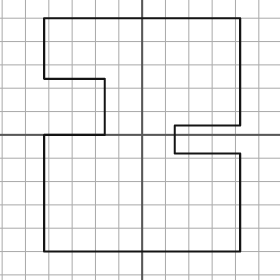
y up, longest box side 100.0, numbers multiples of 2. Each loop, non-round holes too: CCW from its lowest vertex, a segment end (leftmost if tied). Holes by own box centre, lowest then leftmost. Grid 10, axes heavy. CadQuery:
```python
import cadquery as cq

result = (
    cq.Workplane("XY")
    .moveTo(-42.0, -50.0)
    .lineTo(42.0, -50.0)
    .lineTo(42.0, -8.0)
    .lineTo(14.0, -8.0)
    .lineTo(14.0, 4.0)
    .lineTo(42.0, 4.0)
    .lineTo(42.0, 50.0)
    .lineTo(-42.0, 50.0)
    .lineTo(-42.0, 24.0)
    .lineTo(-16.0, 24.0)
    .lineTo(-16.0, 0.0)
    .lineTo(-42.0, 0.0)
    .close()
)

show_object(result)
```